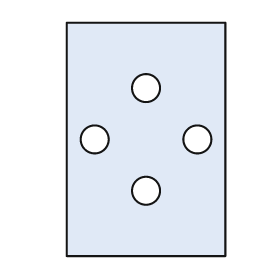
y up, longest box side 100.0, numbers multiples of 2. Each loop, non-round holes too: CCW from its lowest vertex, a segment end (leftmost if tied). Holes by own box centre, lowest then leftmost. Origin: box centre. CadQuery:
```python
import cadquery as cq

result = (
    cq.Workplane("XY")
    .moveTo(-34.0, -50.0)
    .lineTo(34.0, -50.0)
    .lineTo(34.0, 50.0)
    .lineTo(-34.0, 50.0)
    .close()
    .moveTo(0.0, -22.0)
    .circle(6.0)
    .moveTo(-22.0, 0.0)
    .circle(6.0)
    .moveTo(22.0, 0.0)
    .circle(6.0)
    .moveTo(0.0, 22.0)
    .circle(6.0)
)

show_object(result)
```